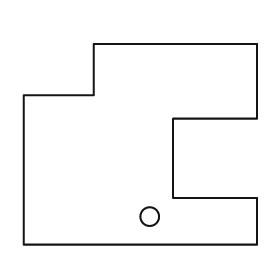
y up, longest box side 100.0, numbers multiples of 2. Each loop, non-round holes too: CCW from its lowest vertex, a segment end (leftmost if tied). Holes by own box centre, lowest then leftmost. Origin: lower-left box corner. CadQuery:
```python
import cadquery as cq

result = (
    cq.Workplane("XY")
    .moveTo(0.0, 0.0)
    .lineTo(100.0, 0.0)
    .lineTo(100.0, 20.0)
    .lineTo(64.0, 20.0)
    .lineTo(64.0, 54.0)
    .lineTo(100.0, 54.0)
    .lineTo(100.0, 86.0)
    .lineTo(30.0, 86.0)
    .lineTo(30.0, 64.0)
    .lineTo(0.0, 64.0)
    .close()
    .moveTo(54.0, 12.0)
    .circle(4.0)
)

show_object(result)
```